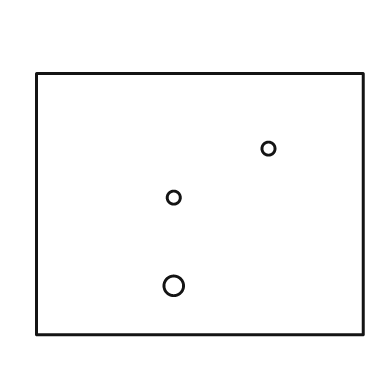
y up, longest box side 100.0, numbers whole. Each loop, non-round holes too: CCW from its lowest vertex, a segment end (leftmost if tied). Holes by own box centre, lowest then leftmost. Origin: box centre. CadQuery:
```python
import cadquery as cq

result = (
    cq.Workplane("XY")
    .moveTo(-50.0, -40.0)
    .lineTo(50.0, -40.0)
    .lineTo(50.0, 40.0)
    .lineTo(-50.0, 40.0)
    .close()
    .moveTo(-8.0, -25.0)
    .circle(3.0)
    .moveTo(-8.0, 2.0)
    .circle(2.0)
    .moveTo(21.0, 17.0)
    .circle(2.0)
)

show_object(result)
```